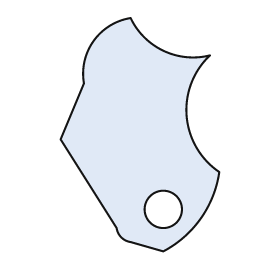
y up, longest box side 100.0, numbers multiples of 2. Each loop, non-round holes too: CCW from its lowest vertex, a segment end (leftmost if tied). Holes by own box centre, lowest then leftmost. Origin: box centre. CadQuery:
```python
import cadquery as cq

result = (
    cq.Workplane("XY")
    .moveTo(10.0, -50.0)
    .threePointArc((26.0, -36.0), (34.0, -16.0))
    .threePointArc((20.0, 8.0), (30.0, 34.0))
    .threePointArc((10.0, 36.0), (-4.0, 50.0))
    .threePointArc((-20.0, 40.0), (-24.0, 22.0))
    .lineTo(-34.0, -2.0)
    .lineTo(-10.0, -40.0)
    .threePointArc((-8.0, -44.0), (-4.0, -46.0))
    .close()
    .moveTo(10.0, -32.0)
    .circle(8.0)
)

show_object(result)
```